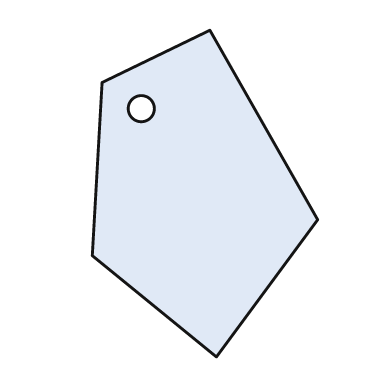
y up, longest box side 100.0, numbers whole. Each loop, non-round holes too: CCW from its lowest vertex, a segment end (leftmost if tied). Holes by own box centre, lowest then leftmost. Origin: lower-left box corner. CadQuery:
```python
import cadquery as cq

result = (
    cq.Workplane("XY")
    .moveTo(38.0, 0.0)
    .lineTo(69.0, 42.0)
    .lineTo(36.0, 100.0)
    .lineTo(3.0, 84.0)
    .lineTo(0.0, 31.0)
    .close()
    .moveTo(15.0, 76.0)
    .circle(4.0)
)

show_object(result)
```